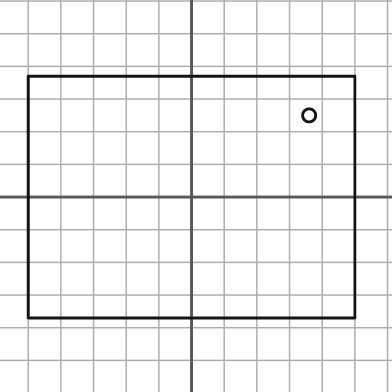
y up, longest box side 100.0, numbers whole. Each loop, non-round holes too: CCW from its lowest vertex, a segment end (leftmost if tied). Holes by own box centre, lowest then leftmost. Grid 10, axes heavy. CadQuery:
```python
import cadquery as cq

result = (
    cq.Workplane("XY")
    .moveTo(-50.0, -37.0)
    .lineTo(50.0, -37.0)
    .lineTo(50.0, 37.0)
    .lineTo(-50.0, 37.0)
    .close()
    .moveTo(36.0, 25.0)
    .circle(2.0)
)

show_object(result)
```